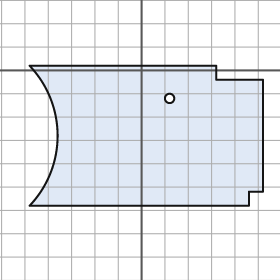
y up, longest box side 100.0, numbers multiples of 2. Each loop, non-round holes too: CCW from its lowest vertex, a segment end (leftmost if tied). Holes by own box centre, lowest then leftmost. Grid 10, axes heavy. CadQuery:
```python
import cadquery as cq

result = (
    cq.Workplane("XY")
    .moveTo(-48.0, -58.0)
    .lineTo(46.0, -58.0)
    .lineTo(46.0, -52.0)
    .lineTo(52.0, -52.0)
    .lineTo(52.0, -4.0)
    .lineTo(32.0, -4.0)
    .lineTo(32.0, 2.0)
    .lineTo(-48.0, 2.0)
    .threePointArc((-36.0, -28.0), (-48.0, -58.0))
    .close()
    .moveTo(12.0, -12.0)
    .circle(2.0)
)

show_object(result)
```